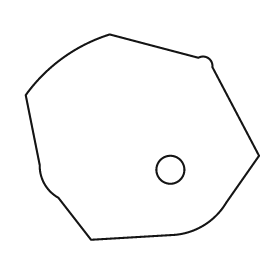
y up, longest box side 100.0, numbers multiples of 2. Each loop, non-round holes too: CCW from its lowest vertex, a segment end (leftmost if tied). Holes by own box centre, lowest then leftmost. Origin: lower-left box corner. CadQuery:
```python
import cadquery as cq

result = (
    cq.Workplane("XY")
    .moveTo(28.0, 0.0)
    .lineTo(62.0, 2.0)
    .threePointArc((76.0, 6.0), (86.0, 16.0))
    .lineTo(100.0, 36.0)
    .lineTo(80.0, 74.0)
    .threePointArc((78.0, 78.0), (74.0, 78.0))
    .lineTo(36.0, 88.0)
    .threePointArc((16.0, 78.0), (0.0, 62.0))
    .lineTo(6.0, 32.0)
    .threePointArc((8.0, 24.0), (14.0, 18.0))
    .close()
    .moveTo(62.0, 30.0)
    .circle(6.0)
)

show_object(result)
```